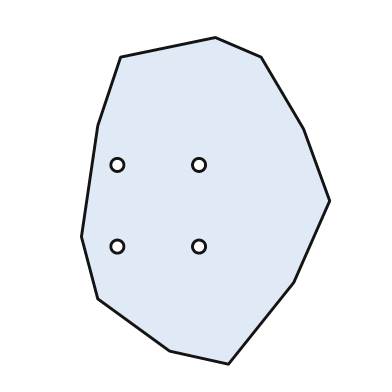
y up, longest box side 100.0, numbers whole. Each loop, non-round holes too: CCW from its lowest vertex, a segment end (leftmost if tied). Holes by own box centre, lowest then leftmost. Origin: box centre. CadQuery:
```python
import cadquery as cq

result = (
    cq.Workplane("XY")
    .moveTo(7.0, -50.0)
    .lineTo(27.0, -25.0)
    .lineTo(38.0, 0.0)
    .lineTo(30.0, 22.0)
    .lineTo(17.0, 44.0)
    .lineTo(3.0, 50.0)
    .lineTo(-26.0, 44.0)
    .lineTo(-33.0, 23.0)
    .lineTo(-38.0, -11.0)
    .lineTo(-33.0, -30.0)
    .lineTo(-11.0, -46.0)
    .close()
    .moveTo(-27.0, -14.0)
    .circle(2.0)
    .moveTo(-2.0, -14.0)
    .circle(2.0)
    .moveTo(-27.0, 11.0)
    .circle(2.0)
    .moveTo(-2.0, 11.0)
    .circle(2.0)
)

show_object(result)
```